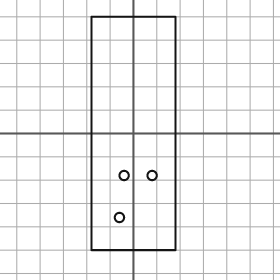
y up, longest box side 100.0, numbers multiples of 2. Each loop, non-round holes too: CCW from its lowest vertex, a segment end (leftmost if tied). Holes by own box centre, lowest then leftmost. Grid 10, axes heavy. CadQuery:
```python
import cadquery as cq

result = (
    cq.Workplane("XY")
    .moveTo(-18.0, -50.0)
    .lineTo(18.0, -50.0)
    .lineTo(18.0, 50.0)
    .lineTo(-18.0, 50.0)
    .close()
    .moveTo(-6.0, -36.0)
    .circle(2.0)
    .moveTo(-4.0, -18.0)
    .circle(2.0)
    .moveTo(8.0, -18.0)
    .circle(2.0)
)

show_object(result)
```